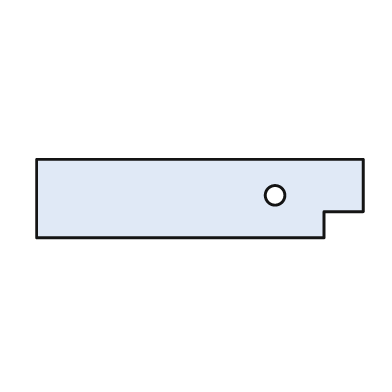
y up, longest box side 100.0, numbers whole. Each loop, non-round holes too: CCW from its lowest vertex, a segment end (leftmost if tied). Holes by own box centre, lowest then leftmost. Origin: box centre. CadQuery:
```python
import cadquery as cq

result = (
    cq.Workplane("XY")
    .moveTo(-50.0, -12.0)
    .lineTo(38.0, -12.0)
    .lineTo(38.0, -4.0)
    .lineTo(50.0, -4.0)
    .lineTo(50.0, 12.0)
    .lineTo(-50.0, 12.0)
    .close()
    .moveTo(23.0, 1.0)
    .circle(3.0)
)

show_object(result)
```